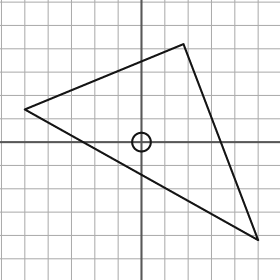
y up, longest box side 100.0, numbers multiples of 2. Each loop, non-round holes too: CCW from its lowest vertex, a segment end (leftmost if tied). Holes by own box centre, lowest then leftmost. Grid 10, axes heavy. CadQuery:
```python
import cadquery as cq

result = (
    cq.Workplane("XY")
    .moveTo(50.0, -42.0)
    .lineTo(18.0, 42.0)
    .lineTo(-50.0, 14.0)
    .close()
    .moveTo(0.0, 0.0)
    .circle(4.0)
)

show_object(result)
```